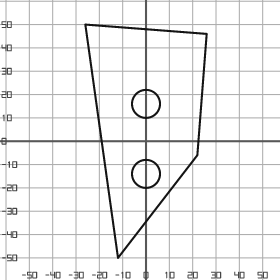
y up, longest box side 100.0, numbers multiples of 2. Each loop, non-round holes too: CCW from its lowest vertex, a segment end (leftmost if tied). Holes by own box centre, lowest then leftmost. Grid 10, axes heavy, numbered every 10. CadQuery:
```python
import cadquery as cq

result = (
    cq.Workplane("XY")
    .moveTo(-12.0, -50.0)
    .lineTo(22.0, -6.0)
    .lineTo(26.0, 46.0)
    .lineTo(-26.0, 50.0)
    .close()
    .moveTo(0.0, -14.0)
    .circle(6.0)
    .moveTo(0.0, 16.0)
    .circle(6.0)
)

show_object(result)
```